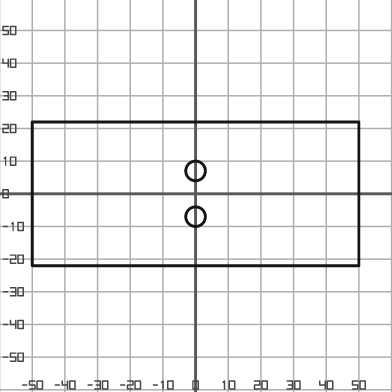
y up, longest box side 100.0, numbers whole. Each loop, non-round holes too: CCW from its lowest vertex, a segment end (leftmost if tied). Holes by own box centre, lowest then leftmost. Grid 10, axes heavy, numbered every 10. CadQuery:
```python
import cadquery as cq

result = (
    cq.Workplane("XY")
    .moveTo(-50.0, -22.0)
    .lineTo(50.0, -22.0)
    .lineTo(50.0, 22.0)
    .lineTo(-50.0, 22.0)
    .close()
    .moveTo(0.0, -7.0)
    .circle(3.0)
    .moveTo(0.0, 7.0)
    .circle(3.0)
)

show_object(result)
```